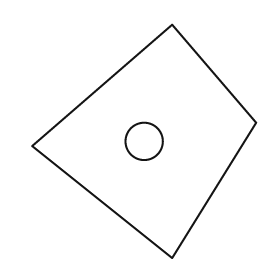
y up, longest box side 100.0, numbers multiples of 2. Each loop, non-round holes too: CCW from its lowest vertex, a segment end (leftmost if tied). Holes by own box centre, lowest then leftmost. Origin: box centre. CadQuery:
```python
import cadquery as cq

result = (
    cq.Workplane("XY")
    .moveTo(12.0, -50.0)
    .lineTo(48.0, 8.0)
    .lineTo(12.0, 50.0)
    .lineTo(-48.0, -2.0)
    .close()
    .moveTo(0.0, 0.0)
    .circle(8.0)
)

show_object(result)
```